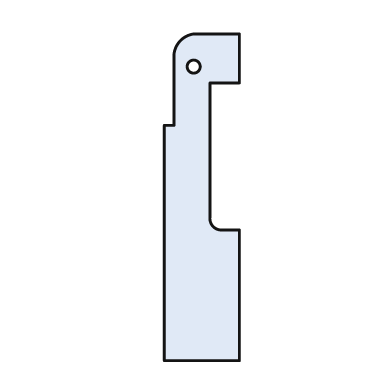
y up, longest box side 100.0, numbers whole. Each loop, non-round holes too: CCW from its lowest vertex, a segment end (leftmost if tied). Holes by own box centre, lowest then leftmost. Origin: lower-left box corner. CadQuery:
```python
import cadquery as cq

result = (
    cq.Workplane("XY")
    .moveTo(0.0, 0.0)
    .lineTo(23.0, 0.0)
    .lineTo(23.0, 40.0)
    .lineTo(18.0, 40.0)
    .threePointArc((15.0, 41.0), (14.0, 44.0))
    .lineTo(14.0, 85.0)
    .lineTo(23.0, 85.0)
    .lineTo(23.0, 100.0)
    .lineTo(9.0, 100.0)
    .threePointArc((5.0, 98.0), (3.0, 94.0))
    .lineTo(3.0, 72.0)
    .lineTo(0.0, 72.0)
    .close()
    .moveTo(9.0, 90.0)
    .circle(2.0)
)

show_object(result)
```